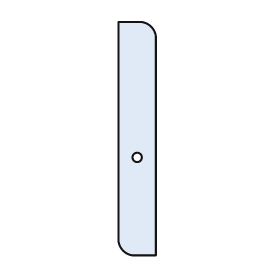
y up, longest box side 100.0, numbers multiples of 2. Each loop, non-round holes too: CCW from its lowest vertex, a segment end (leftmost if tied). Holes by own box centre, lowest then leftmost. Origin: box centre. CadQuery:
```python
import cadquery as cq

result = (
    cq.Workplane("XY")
    .moveTo(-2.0, -50.0)
    .lineTo(8.0, -50.0)
    .lineTo(8.0, 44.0)
    .threePointArc((6.0, 48.0), (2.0, 50.0))
    .lineTo(-8.0, 50.0)
    .lineTo(-8.0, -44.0)
    .threePointArc((-6.0, -48.0), (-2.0, -50.0))
    .close()
    .moveTo(0.0, -8.0)
    .circle(2.0)
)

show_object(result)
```